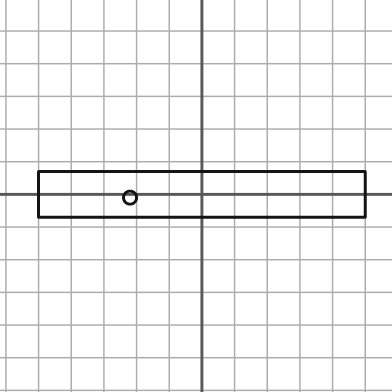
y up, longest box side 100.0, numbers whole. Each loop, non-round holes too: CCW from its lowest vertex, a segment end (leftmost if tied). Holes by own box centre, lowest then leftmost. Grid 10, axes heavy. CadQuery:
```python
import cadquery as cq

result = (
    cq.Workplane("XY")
    .moveTo(-50.0, -7.0)
    .lineTo(50.0, -7.0)
    .lineTo(50.0, 7.0)
    .lineTo(-50.0, 7.0)
    .close()
    .moveTo(-22.0, -1.0)
    .circle(2.0)
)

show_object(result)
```